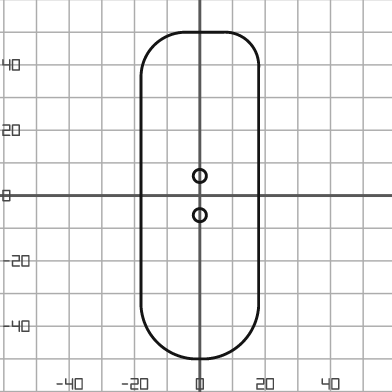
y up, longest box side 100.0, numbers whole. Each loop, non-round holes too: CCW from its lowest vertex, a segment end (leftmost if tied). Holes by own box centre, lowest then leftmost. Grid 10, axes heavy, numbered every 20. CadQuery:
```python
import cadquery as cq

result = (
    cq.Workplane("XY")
    .moveTo(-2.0, -50.0)
    .lineTo(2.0, -50.0)
    .threePointArc((13.0, -45.0), (18.0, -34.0))
    .lineTo(18.0, 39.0)
    .threePointArc((15.0, 47.0), (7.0, 50.0))
    .lineTo(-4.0, 50.0)
    .threePointArc((-14.0, 46.0), (-18.0, 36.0))
    .lineTo(-18.0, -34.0)
    .threePointArc((-13.0, -45.0), (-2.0, -50.0))
    .close()
    .moveTo(0.0, -6.0)
    .circle(2.0)
    .moveTo(0.0, 6.0)
    .circle(2.0)
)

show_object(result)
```